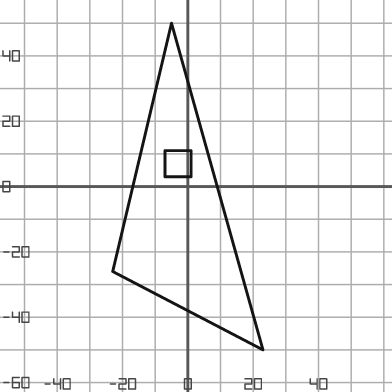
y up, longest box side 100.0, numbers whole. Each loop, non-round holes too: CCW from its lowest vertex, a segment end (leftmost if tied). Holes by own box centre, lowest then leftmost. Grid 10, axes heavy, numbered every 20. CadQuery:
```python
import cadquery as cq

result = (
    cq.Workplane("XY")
    .moveTo(23.0, -50.0)
    .lineTo(-5.0, 50.0)
    .lineTo(-23.0, -26.0)
    .close()
    .moveTo(-7.0, 3.0)
    .lineTo(1.0, 3.0)
    .lineTo(1.0, 11.0)
    .lineTo(-7.0, 11.0)
    .close()
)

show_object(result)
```